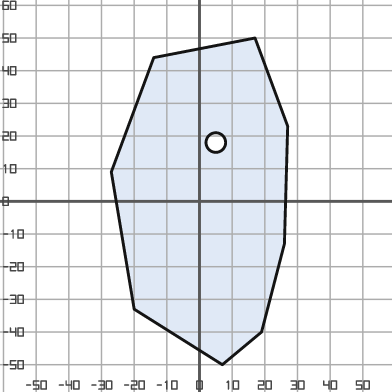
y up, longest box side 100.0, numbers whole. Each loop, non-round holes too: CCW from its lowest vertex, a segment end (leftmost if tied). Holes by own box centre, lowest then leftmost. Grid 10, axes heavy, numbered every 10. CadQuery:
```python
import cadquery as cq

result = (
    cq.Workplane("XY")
    .moveTo(7.0, -50.0)
    .lineTo(19.0, -40.0)
    .lineTo(26.0, -13.0)
    .lineTo(27.0, 23.0)
    .lineTo(17.0, 50.0)
    .lineTo(-14.0, 44.0)
    .lineTo(-27.0, 9.0)
    .lineTo(-20.0, -33.0)
    .close()
    .moveTo(5.0, 18.0)
    .circle(3.0)
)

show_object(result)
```